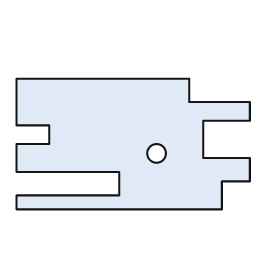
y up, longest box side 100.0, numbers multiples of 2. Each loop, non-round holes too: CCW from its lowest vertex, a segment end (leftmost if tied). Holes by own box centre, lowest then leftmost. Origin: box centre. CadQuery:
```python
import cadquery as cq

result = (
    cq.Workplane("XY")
    .moveTo(-50.0, -28.0)
    .lineTo(38.0, -28.0)
    .lineTo(38.0, -16.0)
    .lineTo(50.0, -16.0)
    .lineTo(50.0, -6.0)
    .lineTo(30.0, -6.0)
    .lineTo(30.0, 10.0)
    .lineTo(50.0, 10.0)
    .lineTo(50.0, 18.0)
    .lineTo(24.0, 18.0)
    .lineTo(24.0, 28.0)
    .lineTo(-50.0, 28.0)
    .lineTo(-50.0, 8.0)
    .lineTo(-36.0, 8.0)
    .lineTo(-36.0, 0.0)
    .lineTo(-50.0, 0.0)
    .lineTo(-50.0, -12.0)
    .lineTo(-6.0, -12.0)
    .lineTo(-6.0, -22.0)
    .lineTo(-50.0, -22.0)
    .close()
    .moveTo(10.0, -4.0)
    .circle(4.0)
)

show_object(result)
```